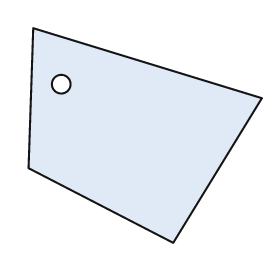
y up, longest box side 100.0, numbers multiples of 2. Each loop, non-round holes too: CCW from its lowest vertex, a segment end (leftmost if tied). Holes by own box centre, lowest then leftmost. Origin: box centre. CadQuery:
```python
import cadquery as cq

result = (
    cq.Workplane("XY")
    .moveTo(12.0, -46.0)
    .lineTo(50.0, 16.0)
    .lineTo(-48.0, 46.0)
    .lineTo(-50.0, -14.0)
    .close()
    .moveTo(-36.0, 22.0)
    .circle(4.0)
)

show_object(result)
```